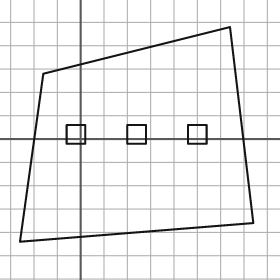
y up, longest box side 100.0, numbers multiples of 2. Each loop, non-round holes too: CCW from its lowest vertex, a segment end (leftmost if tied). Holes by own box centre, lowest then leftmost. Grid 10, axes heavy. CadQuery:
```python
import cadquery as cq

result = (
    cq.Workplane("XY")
    .moveTo(-26.0, -44.0)
    .lineTo(74.0, -36.0)
    .lineTo(64.0, 48.0)
    .lineTo(-16.0, 28.0)
    .close()
    .moveTo(-6.0, -2.0)
    .lineTo(2.0, -2.0)
    .lineTo(2.0, 6.0)
    .lineTo(-6.0, 6.0)
    .close()
    .moveTo(20.0, -2.0)
    .lineTo(28.0, -2.0)
    .lineTo(28.0, 6.0)
    .lineTo(20.0, 6.0)
    .close()
    .moveTo(46.0, -2.0)
    .lineTo(54.0, -2.0)
    .lineTo(54.0, 6.0)
    .lineTo(46.0, 6.0)
    .close()
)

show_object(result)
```